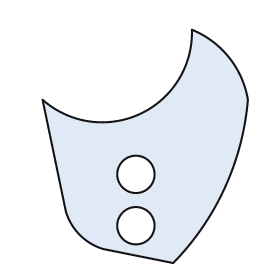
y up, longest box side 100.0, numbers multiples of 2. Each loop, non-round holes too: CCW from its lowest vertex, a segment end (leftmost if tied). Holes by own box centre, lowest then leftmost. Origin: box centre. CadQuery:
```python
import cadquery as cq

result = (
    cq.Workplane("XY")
    .moveTo(12.0, -50.0)
    .threePointArc((34.0, -18.0), (44.0, 20.0))
    .threePointArc((36.0, 38.0), (20.0, 50.0))
    .threePointArc((-2.0, 14.0), (-44.0, 20.0))
    .lineTo(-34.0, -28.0)
    .threePointArc((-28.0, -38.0), (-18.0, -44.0))
    .close()
    .moveTo(-4.0, -34.0)
    .circle(8.0)
    .moveTo(-4.0, -12.0)
    .circle(8.0)
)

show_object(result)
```